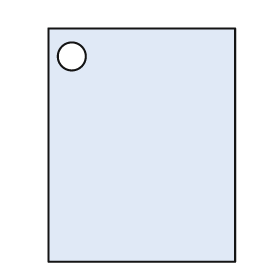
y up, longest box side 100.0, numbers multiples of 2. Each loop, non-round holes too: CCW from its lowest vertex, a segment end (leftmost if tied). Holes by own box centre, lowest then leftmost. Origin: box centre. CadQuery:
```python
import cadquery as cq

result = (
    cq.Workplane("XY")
    .moveTo(-40.0, -50.0)
    .lineTo(40.0, -50.0)
    .lineTo(40.0, 50.0)
    .lineTo(-40.0, 50.0)
    .close()
    .moveTo(-30.0, 38.0)
    .circle(6.0)
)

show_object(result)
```